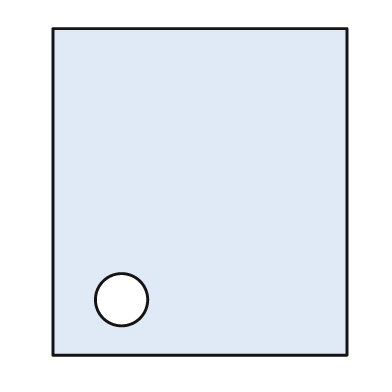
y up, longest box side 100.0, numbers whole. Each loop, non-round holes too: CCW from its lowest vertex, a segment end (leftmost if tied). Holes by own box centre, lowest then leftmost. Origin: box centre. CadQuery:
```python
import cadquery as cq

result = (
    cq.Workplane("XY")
    .moveTo(-45.0, -50.0)
    .lineTo(45.0, -50.0)
    .lineTo(45.0, 50.0)
    .lineTo(-45.0, 50.0)
    .close()
    .moveTo(-24.0, -33.0)
    .circle(8.0)
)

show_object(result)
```